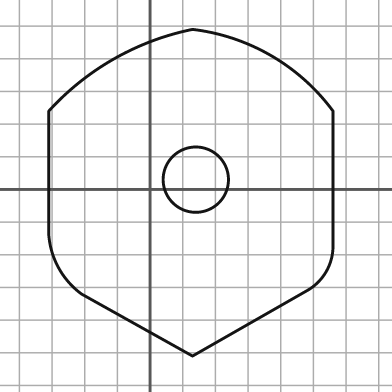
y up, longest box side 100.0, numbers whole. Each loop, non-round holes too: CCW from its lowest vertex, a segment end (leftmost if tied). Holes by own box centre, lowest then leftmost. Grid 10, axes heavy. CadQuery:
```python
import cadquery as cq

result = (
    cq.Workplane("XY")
    .moveTo(13.0, -51.0)
    .lineTo(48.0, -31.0)
    .threePointArc((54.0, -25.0), (56.0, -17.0))
    .lineTo(56.0, 24.0)
    .threePointArc((37.0, 41.0), (13.0, 49.0))
    .threePointArc((-11.0, 40.0), (-31.0, 24.0))
    .lineTo(-31.0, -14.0)
    .threePointArc((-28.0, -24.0), (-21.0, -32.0))
    .close()
    .moveTo(14.0, 3.0)
    .circle(10.0)
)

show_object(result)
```